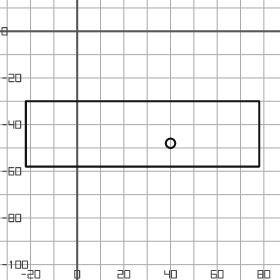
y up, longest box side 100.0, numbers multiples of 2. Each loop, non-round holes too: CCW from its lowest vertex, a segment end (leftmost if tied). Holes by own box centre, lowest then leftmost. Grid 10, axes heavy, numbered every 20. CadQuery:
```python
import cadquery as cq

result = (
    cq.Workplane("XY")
    .moveTo(-22.0, -58.0)
    .lineTo(78.0, -58.0)
    .lineTo(78.0, -30.0)
    .lineTo(-22.0, -30.0)
    .close()
    .moveTo(40.0, -48.0)
    .circle(2.0)
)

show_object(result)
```